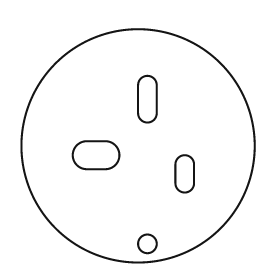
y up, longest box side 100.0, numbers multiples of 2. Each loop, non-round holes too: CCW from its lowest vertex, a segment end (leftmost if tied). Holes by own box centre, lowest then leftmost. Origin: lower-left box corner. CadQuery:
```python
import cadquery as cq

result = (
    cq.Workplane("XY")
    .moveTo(50.0, 50.0)
    .circle(50.0)
    .moveTo(54.0, 8.0)
    .circle(4.0)
    .moveTo(66.0, 34.0)
    .threePointArc((70.0, 30.0), (74.0, 34.0))
    .lineTo(74.0, 42.0)
    .threePointArc((70.0, 46.0), (66.0, 42.0))
    .close()
    .moveTo(28.0, 40.0)
    .lineTo(36.0, 40.0)
    .threePointArc((42.0, 46.0), (36.0, 52.0))
    .lineTo(28.0, 52.0)
    .threePointArc((22.0, 46.0), (28.0, 40.0))
    .close()
    .moveTo(50.0, 64.0)
    .threePointArc((54.0, 60.0), (58.0, 64.0))
    .lineTo(58.0, 76.0)
    .threePointArc((54.0, 80.0), (50.0, 76.0))
    .close()
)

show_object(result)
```